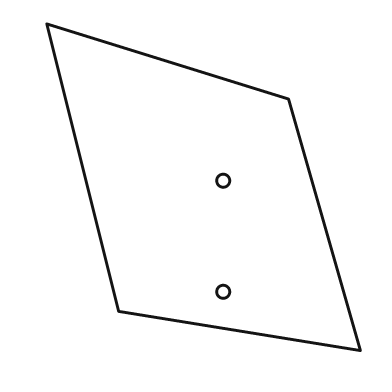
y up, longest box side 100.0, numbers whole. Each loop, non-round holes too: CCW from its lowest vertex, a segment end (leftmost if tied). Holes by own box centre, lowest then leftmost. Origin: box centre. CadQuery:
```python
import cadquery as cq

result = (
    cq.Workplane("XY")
    .moveTo(48.0, -50.0)
    .lineTo(26.0, 27.0)
    .lineTo(-48.0, 50.0)
    .lineTo(-26.0, -38.0)
    .close()
    .moveTo(6.0, -32.0)
    .circle(2.0)
    .moveTo(6.0, 2.0)
    .circle(2.0)
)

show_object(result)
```